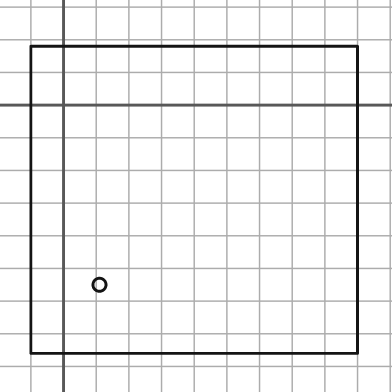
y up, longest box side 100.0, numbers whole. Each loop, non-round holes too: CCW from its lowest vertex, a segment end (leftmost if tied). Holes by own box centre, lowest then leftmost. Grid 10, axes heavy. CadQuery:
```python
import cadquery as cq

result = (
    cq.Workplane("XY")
    .moveTo(-10.0, -76.0)
    .lineTo(90.0, -76.0)
    .lineTo(90.0, 18.0)
    .lineTo(-10.0, 18.0)
    .close()
    .moveTo(11.0, -55.0)
    .circle(2.0)
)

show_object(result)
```